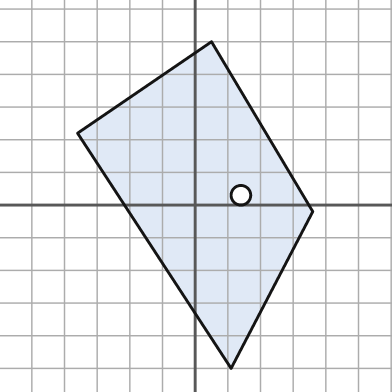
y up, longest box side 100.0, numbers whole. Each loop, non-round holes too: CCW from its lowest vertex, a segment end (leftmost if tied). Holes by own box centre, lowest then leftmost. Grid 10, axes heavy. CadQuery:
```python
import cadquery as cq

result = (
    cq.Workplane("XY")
    .moveTo(11.0, -50.0)
    .lineTo(36.0, -2.0)
    .lineTo(5.0, 50.0)
    .lineTo(-36.0, 22.0)
    .close()
    .moveTo(14.0, 3.0)
    .circle(3.0)
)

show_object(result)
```